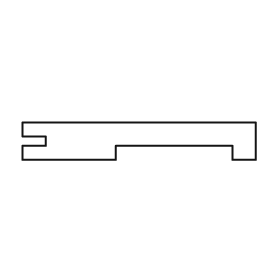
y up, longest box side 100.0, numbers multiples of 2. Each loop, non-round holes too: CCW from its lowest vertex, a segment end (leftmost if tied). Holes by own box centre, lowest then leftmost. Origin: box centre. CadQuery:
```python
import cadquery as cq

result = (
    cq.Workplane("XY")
    .moveTo(-50.0, -8.0)
    .lineTo(-10.0, -8.0)
    .lineTo(-10.0, -2.0)
    .lineTo(40.0, -2.0)
    .lineTo(40.0, -8.0)
    .lineTo(50.0, -8.0)
    .lineTo(50.0, 8.0)
    .lineTo(-50.0, 8.0)
    .lineTo(-50.0, 2.0)
    .lineTo(-40.0, 2.0)
    .lineTo(-40.0, -2.0)
    .lineTo(-50.0, -2.0)
    .close()
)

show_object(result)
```